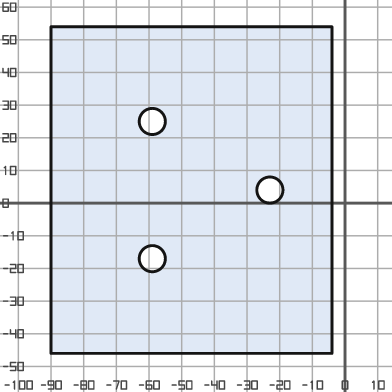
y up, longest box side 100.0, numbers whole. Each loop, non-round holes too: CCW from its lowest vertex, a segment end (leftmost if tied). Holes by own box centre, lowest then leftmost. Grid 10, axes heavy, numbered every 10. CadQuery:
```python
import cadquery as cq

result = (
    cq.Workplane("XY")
    .moveTo(-90.0, -46.0)
    .lineTo(-4.0, -46.0)
    .lineTo(-4.0, 54.0)
    .lineTo(-90.0, 54.0)
    .close()
    .moveTo(-59.0, -17.0)
    .circle(4.0)
    .moveTo(-23.0, 4.0)
    .circle(4.0)
    .moveTo(-59.0, 25.0)
    .circle(4.0)
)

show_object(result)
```